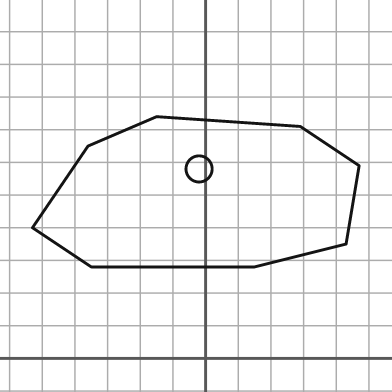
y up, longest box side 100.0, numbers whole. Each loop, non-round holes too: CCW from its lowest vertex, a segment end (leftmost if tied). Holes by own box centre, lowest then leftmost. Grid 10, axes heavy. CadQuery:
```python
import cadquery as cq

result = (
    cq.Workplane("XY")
    .moveTo(-35.0, 28.0)
    .lineTo(15.0, 28.0)
    .lineTo(43.0, 35.0)
    .lineTo(47.0, 59.0)
    .lineTo(29.0, 71.0)
    .lineTo(-15.0, 74.0)
    .lineTo(-36.0, 65.0)
    .lineTo(-53.0, 40.0)
    .close()
    .moveTo(-2.0, 58.0)
    .circle(4.0)
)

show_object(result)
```